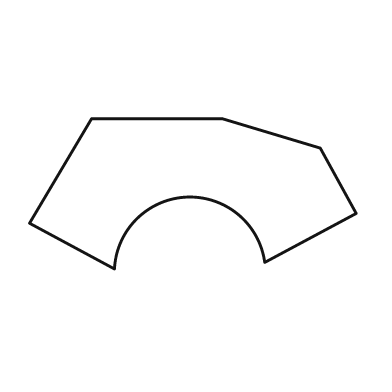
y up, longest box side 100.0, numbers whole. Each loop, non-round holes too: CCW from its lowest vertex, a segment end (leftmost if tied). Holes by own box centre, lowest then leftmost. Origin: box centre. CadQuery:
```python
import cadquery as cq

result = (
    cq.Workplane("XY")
    .moveTo(-24.0, -23.0)
    .threePointArc((-2.0, -1.0), (22.0, -21.0))
    .lineTo(50.0, -6.0)
    .lineTo(39.0, 14.0)
    .lineTo(9.0, 23.0)
    .lineTo(-31.0, 23.0)
    .lineTo(-50.0, -9.0)
    .close()
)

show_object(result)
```